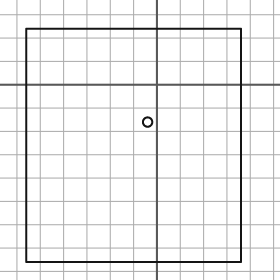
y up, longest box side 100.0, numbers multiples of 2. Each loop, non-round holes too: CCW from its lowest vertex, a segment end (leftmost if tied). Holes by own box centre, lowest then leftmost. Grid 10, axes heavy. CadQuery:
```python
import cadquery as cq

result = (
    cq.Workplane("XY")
    .moveTo(-56.0, -76.0)
    .lineTo(36.0, -76.0)
    .lineTo(36.0, 24.0)
    .lineTo(-56.0, 24.0)
    .close()
    .moveTo(-4.0, -16.0)
    .circle(2.0)
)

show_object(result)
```